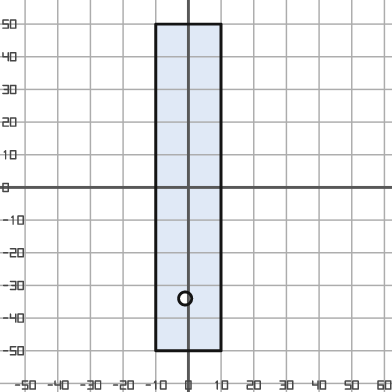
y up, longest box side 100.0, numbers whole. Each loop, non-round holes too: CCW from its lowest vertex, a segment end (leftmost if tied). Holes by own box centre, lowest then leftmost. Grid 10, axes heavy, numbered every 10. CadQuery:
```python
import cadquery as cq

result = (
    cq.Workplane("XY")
    .moveTo(-10.0, -50.0)
    .lineTo(10.0, -50.0)
    .lineTo(10.0, 50.0)
    .lineTo(-10.0, 50.0)
    .close()
    .moveTo(-1.0, -34.0)
    .circle(2.0)
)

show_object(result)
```